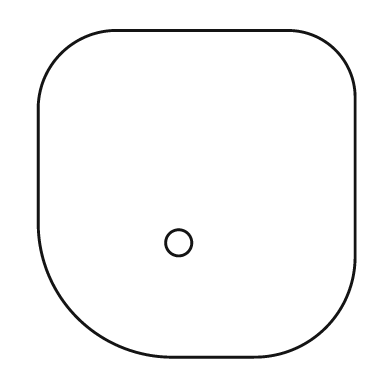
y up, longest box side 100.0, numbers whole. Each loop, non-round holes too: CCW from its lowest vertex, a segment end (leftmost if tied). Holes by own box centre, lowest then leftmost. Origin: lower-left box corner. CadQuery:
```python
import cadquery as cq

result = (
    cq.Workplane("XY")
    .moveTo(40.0, 0.0)
    .lineTo(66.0, 0.0)
    .threePointArc((88.0, 9.0), (97.0, 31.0))
    .lineTo(97.0, 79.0)
    .threePointArc((91.0, 94.0), (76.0, 100.0))
    .lineTo(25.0, 100.0)
    .threePointArc((7.0, 93.0), (0.0, 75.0))
    .lineTo(0.0, 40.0)
    .threePointArc((12.0, 12.0), (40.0, 0.0))
    .close()
    .moveTo(43.0, 35.0)
    .circle(4.0)
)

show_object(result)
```